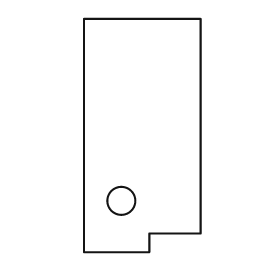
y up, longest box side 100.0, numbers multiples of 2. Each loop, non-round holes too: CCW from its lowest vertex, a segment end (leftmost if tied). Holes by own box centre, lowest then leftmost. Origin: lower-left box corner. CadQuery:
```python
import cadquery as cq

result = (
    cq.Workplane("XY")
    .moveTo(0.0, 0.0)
    .lineTo(28.0, 0.0)
    .lineTo(28.0, 8.0)
    .lineTo(50.0, 8.0)
    .lineTo(50.0, 100.0)
    .lineTo(0.0, 100.0)
    .close()
    .moveTo(16.0, 22.0)
    .circle(6.0)
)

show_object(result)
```